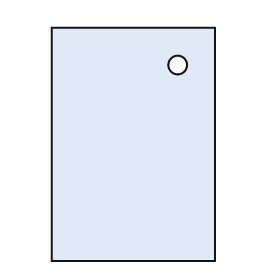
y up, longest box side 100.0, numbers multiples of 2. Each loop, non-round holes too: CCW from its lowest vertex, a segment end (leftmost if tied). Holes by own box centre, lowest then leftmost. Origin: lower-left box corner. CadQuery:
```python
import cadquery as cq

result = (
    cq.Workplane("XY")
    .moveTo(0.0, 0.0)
    .lineTo(70.0, 0.0)
    .lineTo(70.0, 100.0)
    .lineTo(0.0, 100.0)
    .close()
    .moveTo(54.0, 84.0)
    .circle(4.0)
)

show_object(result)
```